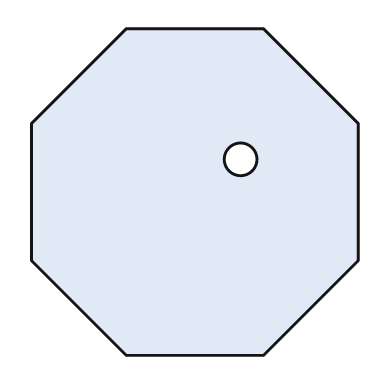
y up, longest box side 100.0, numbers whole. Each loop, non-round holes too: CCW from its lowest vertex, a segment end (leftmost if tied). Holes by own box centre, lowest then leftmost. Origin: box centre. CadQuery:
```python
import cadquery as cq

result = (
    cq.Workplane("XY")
    .moveTo(-21.0, -50.0)
    .lineTo(21.0, -50.0)
    .lineTo(50.0, -21.0)
    .lineTo(50.0, 21.0)
    .lineTo(21.0, 50.0)
    .lineTo(-21.0, 50.0)
    .lineTo(-50.0, 21.0)
    .lineTo(-50.0, -21.0)
    .close()
    .moveTo(14.0, 10.0)
    .circle(5.0)
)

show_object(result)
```